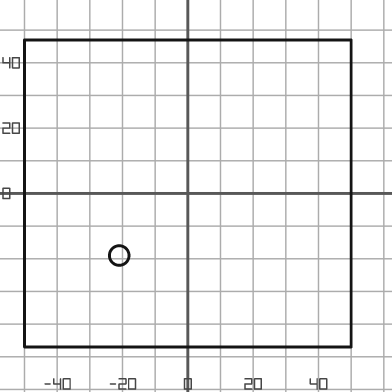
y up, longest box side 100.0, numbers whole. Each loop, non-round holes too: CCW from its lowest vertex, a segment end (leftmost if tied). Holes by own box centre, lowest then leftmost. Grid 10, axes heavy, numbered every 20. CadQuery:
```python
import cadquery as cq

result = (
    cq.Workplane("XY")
    .moveTo(-50.0, -47.0)
    .lineTo(50.0, -47.0)
    .lineTo(50.0, 47.0)
    .lineTo(-50.0, 47.0)
    .close()
    .moveTo(-21.0, -19.0)
    .circle(3.0)
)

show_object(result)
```